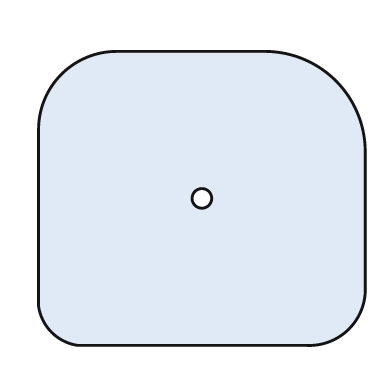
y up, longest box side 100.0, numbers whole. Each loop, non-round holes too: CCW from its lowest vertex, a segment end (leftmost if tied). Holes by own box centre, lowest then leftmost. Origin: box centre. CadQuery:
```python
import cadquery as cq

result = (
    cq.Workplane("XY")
    .moveTo(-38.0, -45.0)
    .lineTo(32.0, -45.0)
    .threePointArc((45.0, -40.0), (50.0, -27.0))
    .lineTo(50.0, 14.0)
    .threePointArc((41.0, 36.0), (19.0, 45.0))
    .lineTo(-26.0, 45.0)
    .threePointArc((-43.0, 38.0), (-50.0, 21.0))
    .lineTo(-50.0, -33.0)
    .threePointArc((-46.0, -41.0), (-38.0, -45.0))
    .close()
    .moveTo(0.0, 0.0)
    .circle(3.0)
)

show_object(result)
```